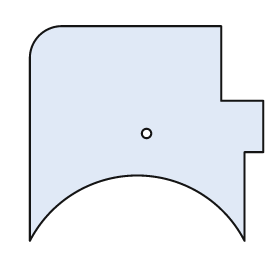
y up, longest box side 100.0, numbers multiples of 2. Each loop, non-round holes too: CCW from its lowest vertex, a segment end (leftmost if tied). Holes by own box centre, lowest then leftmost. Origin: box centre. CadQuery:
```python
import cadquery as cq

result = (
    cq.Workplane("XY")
    .moveTo(-50.0, -46.0)
    .threePointArc((-4.0, -18.0), (42.0, -46.0))
    .lineTo(42.0, -8.0)
    .lineTo(50.0, -8.0)
    .lineTo(50.0, 14.0)
    .lineTo(32.0, 14.0)
    .lineTo(32.0, 46.0)
    .lineTo(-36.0, 46.0)
    .threePointArc((-46.0, 42.0), (-50.0, 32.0))
    .close()
    .moveTo(0.0, 0.0)
    .circle(2.0)
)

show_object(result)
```